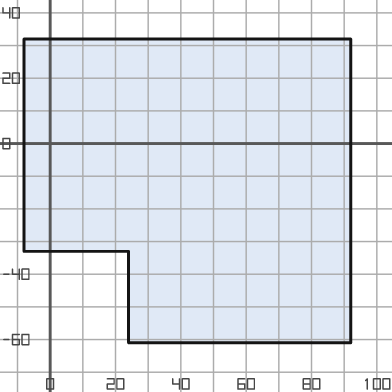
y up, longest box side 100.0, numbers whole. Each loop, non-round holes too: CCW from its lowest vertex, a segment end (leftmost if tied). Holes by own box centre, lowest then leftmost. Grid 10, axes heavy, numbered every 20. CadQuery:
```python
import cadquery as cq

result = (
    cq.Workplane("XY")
    .moveTo(24.0, -61.0)
    .lineTo(92.0, -61.0)
    .lineTo(92.0, 32.0)
    .lineTo(-8.0, 32.0)
    .lineTo(-8.0, -33.0)
    .lineTo(24.0, -33.0)
    .close()
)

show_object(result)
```